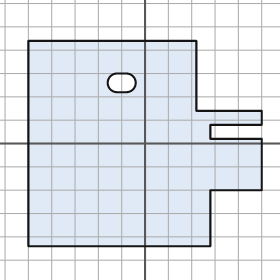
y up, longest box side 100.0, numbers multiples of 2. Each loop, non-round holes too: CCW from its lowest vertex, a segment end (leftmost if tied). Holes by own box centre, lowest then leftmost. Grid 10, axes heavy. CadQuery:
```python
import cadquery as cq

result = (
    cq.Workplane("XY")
    .moveTo(-50.0, -44.0)
    .lineTo(28.0, -44.0)
    .lineTo(28.0, -20.0)
    .lineTo(50.0, -20.0)
    .lineTo(50.0, 2.0)
    .lineTo(28.0, 2.0)
    .lineTo(28.0, 8.0)
    .lineTo(50.0, 8.0)
    .lineTo(50.0, 14.0)
    .lineTo(22.0, 14.0)
    .lineTo(22.0, 44.0)
    .lineTo(-50.0, 44.0)
    .close()
    .moveTo(-12.0, 22.0)
    .lineTo(-8.0, 22.0)
    .threePointArc((-4.0, 26.0), (-8.0, 30.0))
    .lineTo(-12.0, 30.0)
    .threePointArc((-16.0, 26.0), (-12.0, 22.0))
    .close()
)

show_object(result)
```